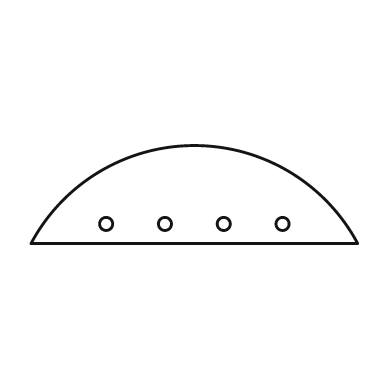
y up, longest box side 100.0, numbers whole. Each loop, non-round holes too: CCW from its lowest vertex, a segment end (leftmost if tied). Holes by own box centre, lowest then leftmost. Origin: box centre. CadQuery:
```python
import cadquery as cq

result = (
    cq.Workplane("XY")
    .moveTo(-50.0, -15.0)
    .lineTo(50.0, -15.0)
    .threePointArc((0.0, 15.0), (-50.0, -15.0))
    .close()
    .moveTo(-27.0, -9.0)
    .circle(2.0)
    .moveTo(-9.0, -9.0)
    .circle(2.0)
    .moveTo(9.0, -9.0)
    .circle(2.0)
    .moveTo(27.0, -9.0)
    .circle(2.0)
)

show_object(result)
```